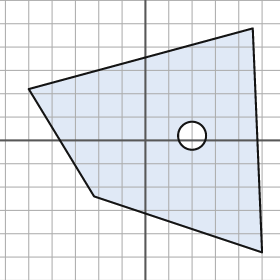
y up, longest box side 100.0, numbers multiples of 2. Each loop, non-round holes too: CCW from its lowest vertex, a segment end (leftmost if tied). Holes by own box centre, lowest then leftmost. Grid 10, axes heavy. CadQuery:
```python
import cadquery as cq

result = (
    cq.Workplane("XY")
    .moveTo(50.0, -48.0)
    .lineTo(46.0, 48.0)
    .lineTo(-50.0, 22.0)
    .lineTo(-22.0, -24.0)
    .close()
    .moveTo(20.0, 2.0)
    .circle(6.0)
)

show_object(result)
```